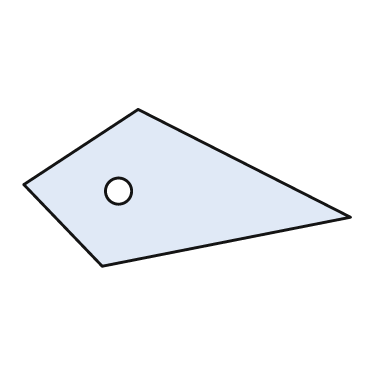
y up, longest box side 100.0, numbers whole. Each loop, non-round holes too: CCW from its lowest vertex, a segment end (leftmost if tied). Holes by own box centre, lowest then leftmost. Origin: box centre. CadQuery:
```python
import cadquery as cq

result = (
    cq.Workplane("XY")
    .moveTo(-26.0, -24.0)
    .lineTo(50.0, -9.0)
    .lineTo(-15.0, 24.0)
    .lineTo(-50.0, 1.0)
    .close()
    .moveTo(-21.0, -1.0)
    .circle(4.0)
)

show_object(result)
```